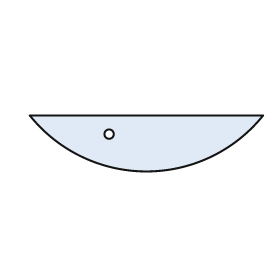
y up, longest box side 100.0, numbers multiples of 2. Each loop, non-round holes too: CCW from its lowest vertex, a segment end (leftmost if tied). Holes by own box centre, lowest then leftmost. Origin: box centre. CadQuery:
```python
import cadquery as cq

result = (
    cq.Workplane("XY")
    .moveTo(-50.0, 12.0)
    .threePointArc((0.0, -12.0), (50.0, 12.0))
    .close()
    .moveTo(-16.0, 4.0)
    .circle(2.0)
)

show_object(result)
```